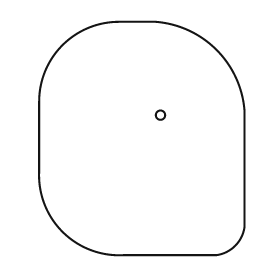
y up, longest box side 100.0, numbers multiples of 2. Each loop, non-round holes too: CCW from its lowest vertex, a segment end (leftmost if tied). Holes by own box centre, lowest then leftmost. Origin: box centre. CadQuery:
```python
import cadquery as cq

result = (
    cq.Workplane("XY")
    .moveTo(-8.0, -50.0)
    .lineTo(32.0, -50.0)
    .threePointArc((40.0, -46.0), (44.0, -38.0))
    .lineTo(44.0, 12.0)
    .threePointArc((32.0, 38.0), (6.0, 50.0))
    .lineTo(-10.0, 50.0)
    .threePointArc((-34.0, 40.0), (-44.0, 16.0))
    .lineTo(-44.0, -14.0)
    .threePointArc((-34.0, -40.0), (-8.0, -50.0))
    .close()
    .moveTo(8.0, 10.0)
    .circle(2.0)
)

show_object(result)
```